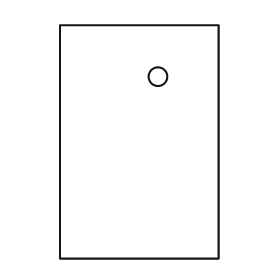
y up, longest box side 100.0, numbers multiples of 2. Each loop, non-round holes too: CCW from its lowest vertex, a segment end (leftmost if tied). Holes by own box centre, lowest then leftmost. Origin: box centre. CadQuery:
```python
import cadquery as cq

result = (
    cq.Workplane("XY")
    .moveTo(-34.0, -50.0)
    .lineTo(34.0, -50.0)
    .lineTo(34.0, 50.0)
    .lineTo(-34.0, 50.0)
    .close()
    .moveTo(8.0, 28.0)
    .circle(4.0)
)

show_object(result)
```